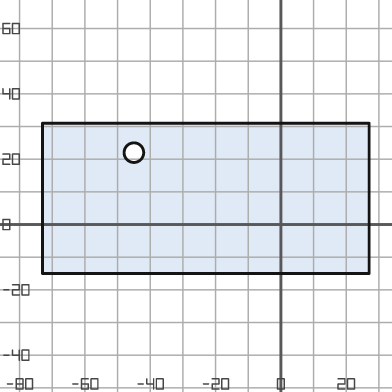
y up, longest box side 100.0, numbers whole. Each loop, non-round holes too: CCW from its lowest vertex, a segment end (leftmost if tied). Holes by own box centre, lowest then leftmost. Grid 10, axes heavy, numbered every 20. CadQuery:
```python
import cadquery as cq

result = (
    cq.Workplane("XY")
    .moveTo(-73.0, -15.0)
    .lineTo(27.0, -15.0)
    .lineTo(27.0, 31.0)
    .lineTo(-73.0, 31.0)
    .close()
    .moveTo(-45.0, 22.0)
    .circle(3.0)
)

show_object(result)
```